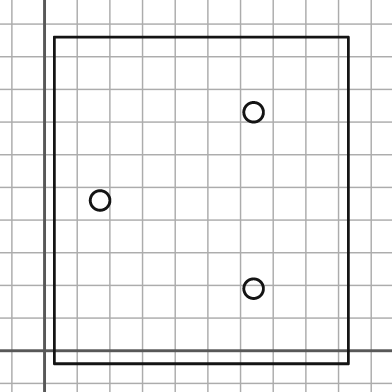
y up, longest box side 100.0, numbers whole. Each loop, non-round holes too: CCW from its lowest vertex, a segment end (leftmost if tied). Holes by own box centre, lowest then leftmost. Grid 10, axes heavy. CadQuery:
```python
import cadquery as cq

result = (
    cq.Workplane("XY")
    .moveTo(3.0, -4.0)
    .lineTo(93.0, -4.0)
    .lineTo(93.0, 96.0)
    .lineTo(3.0, 96.0)
    .close()
    .moveTo(64.0, 19.0)
    .circle(3.0)
    .moveTo(17.0, 46.0)
    .circle(3.0)
    .moveTo(64.0, 73.0)
    .circle(3.0)
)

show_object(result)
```